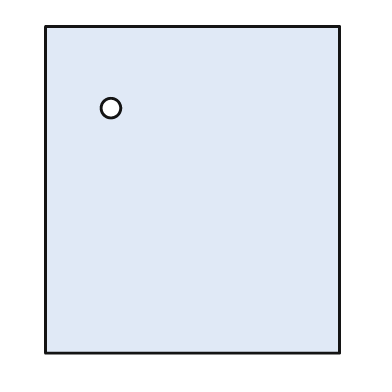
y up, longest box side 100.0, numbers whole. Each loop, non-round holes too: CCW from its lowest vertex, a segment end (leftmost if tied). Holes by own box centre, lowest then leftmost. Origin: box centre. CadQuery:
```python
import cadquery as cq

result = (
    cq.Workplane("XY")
    .moveTo(-45.0, -50.0)
    .lineTo(45.0, -50.0)
    .lineTo(45.0, 50.0)
    .lineTo(-45.0, 50.0)
    .close()
    .moveTo(-25.0, 25.0)
    .circle(3.0)
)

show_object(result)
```